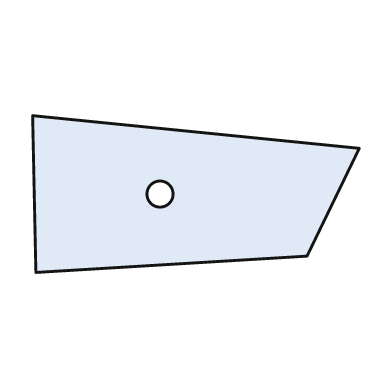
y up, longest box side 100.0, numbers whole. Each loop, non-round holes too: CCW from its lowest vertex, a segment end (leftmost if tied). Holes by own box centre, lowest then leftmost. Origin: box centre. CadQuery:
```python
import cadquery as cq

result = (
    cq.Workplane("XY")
    .moveTo(-49.0, -24.0)
    .lineTo(34.0, -19.0)
    .lineTo(50.0, 14.0)
    .lineTo(-50.0, 24.0)
    .close()
    .moveTo(-11.0, 0.0)
    .circle(4.0)
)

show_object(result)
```